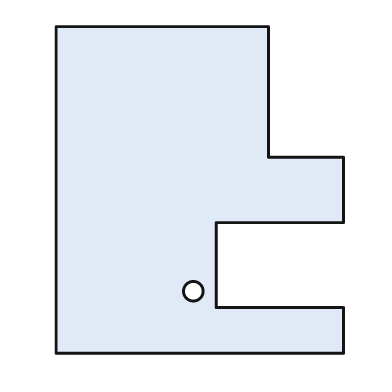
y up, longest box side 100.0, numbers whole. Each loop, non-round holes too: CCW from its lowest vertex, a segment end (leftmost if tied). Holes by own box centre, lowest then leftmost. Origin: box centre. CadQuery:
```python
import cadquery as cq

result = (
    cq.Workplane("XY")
    .moveTo(-44.0, -50.0)
    .lineTo(44.0, -50.0)
    .lineTo(44.0, -36.0)
    .lineTo(5.0, -36.0)
    .lineTo(5.0, -10.0)
    .lineTo(44.0, -10.0)
    .lineTo(44.0, 10.0)
    .lineTo(21.0, 10.0)
    .lineTo(21.0, 50.0)
    .lineTo(-44.0, 50.0)
    .close()
    .moveTo(-2.0, -31.0)
    .circle(3.0)
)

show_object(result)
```